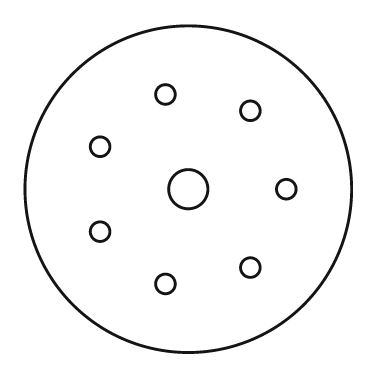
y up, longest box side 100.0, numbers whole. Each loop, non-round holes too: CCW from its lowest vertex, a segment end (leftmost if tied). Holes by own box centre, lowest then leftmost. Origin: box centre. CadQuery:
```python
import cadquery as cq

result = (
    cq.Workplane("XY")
    .moveTo(0.0, 0.0)
    .circle(50.0)
    .moveTo(-7.0, -29.0)
    .circle(3.0)
    .moveTo(19.0, -24.0)
    .circle(3.0)
    .moveTo(-27.0, -13.0)
    .circle(3.0)
    .moveTo(0.0, 0.0)
    .circle(6.0)
    .moveTo(30.0, 0.0)
    .circle(3.0)
    .moveTo(-27.0, 13.0)
    .circle(3.0)
    .moveTo(19.0, 24.0)
    .circle(3.0)
    .moveTo(-7.0, 29.0)
    .circle(3.0)
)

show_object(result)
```